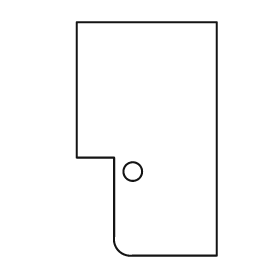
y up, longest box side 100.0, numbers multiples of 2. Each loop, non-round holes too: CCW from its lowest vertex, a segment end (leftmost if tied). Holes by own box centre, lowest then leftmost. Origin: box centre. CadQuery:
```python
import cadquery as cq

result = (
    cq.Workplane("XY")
    .moveTo(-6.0, -50.0)
    .lineTo(30.0, -50.0)
    .lineTo(30.0, 50.0)
    .lineTo(-30.0, 50.0)
    .lineTo(-30.0, -8.0)
    .lineTo(-14.0, -8.0)
    .lineTo(-14.0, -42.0)
    .threePointArc((-12.0, -48.0), (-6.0, -50.0))
    .close()
    .moveTo(-6.0, -14.0)
    .circle(4.0)
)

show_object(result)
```